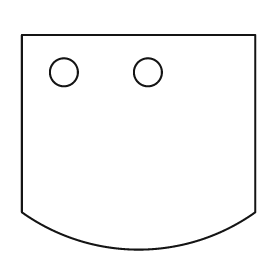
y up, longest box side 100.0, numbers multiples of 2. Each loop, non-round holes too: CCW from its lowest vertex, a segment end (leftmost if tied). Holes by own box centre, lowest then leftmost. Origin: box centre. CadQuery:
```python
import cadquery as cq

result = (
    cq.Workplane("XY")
    .moveTo(-50.0, -30.0)
    .threePointArc((0.0, -46.0), (50.0, -30.0))
    .lineTo(50.0, 46.0)
    .lineTo(-50.0, 46.0)
    .close()
    .moveTo(-32.0, 30.0)
    .circle(6.0)
    .moveTo(4.0, 30.0)
    .circle(6.0)
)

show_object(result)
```